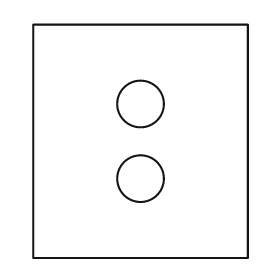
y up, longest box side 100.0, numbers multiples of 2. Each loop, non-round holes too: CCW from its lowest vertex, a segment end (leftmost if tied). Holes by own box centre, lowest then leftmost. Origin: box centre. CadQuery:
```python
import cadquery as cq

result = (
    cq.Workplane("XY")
    .moveTo(-46.0, -50.0)
    .lineTo(46.0, -50.0)
    .lineTo(46.0, 50.0)
    .lineTo(-46.0, 50.0)
    .close()
    .moveTo(0.0, -16.0)
    .circle(10.0)
    .moveTo(0.0, 16.0)
    .circle(10.0)
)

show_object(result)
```